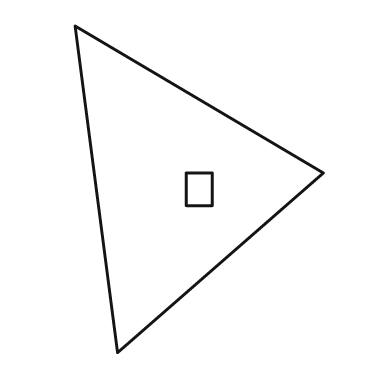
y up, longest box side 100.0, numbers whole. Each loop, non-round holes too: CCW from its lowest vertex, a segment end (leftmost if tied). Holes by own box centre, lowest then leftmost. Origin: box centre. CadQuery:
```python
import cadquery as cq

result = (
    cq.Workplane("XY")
    .moveTo(-25.0, -50.0)
    .lineTo(38.0, 5.0)
    .lineTo(-38.0, 50.0)
    .close()
    .moveTo(-4.0, -5.0)
    .lineTo(4.0, -5.0)
    .lineTo(4.0, 5.0)
    .lineTo(-4.0, 5.0)
    .close()
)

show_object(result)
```